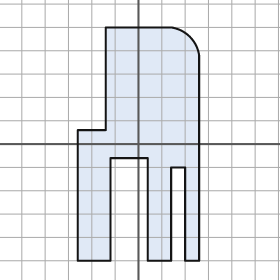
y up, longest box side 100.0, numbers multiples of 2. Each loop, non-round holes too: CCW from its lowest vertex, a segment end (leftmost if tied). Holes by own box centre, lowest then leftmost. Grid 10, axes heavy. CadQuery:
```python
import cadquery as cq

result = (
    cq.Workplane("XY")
    .moveTo(-26.0, -50.0)
    .lineTo(-12.0, -50.0)
    .lineTo(-12.0, -6.0)
    .lineTo(4.0, -6.0)
    .lineTo(4.0, -50.0)
    .lineTo(14.0, -50.0)
    .lineTo(14.0, -10.0)
    .lineTo(20.0, -10.0)
    .lineTo(20.0, -50.0)
    .lineTo(26.0, -50.0)
    .lineTo(26.0, 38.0)
    .threePointArc((22.0, 46.0), (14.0, 50.0))
    .lineTo(-14.0, 50.0)
    .lineTo(-14.0, 6.0)
    .lineTo(-26.0, 6.0)
    .close()
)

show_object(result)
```